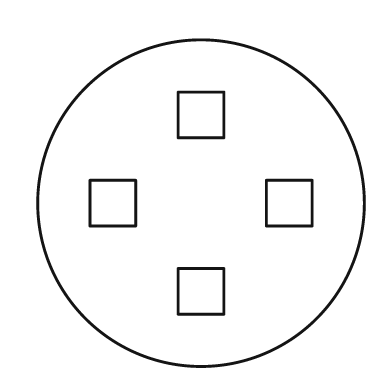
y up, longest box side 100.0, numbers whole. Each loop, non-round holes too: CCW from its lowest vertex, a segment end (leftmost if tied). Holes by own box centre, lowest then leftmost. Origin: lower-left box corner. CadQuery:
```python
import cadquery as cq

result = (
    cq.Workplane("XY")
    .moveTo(50.0, 50.0)
    .circle(50.0)
    .moveTo(43.0, 16.0)
    .lineTo(57.0, 16.0)
    .lineTo(57.0, 30.0)
    .lineTo(43.0, 30.0)
    .close()
    .moveTo(16.0, 43.0)
    .lineTo(30.0, 43.0)
    .lineTo(30.0, 57.0)
    .lineTo(16.0, 57.0)
    .close()
    .moveTo(70.0, 43.0)
    .lineTo(84.0, 43.0)
    .lineTo(84.0, 57.0)
    .lineTo(70.0, 57.0)
    .close()
    .moveTo(43.0, 70.0)
    .lineTo(57.0, 70.0)
    .lineTo(57.0, 84.0)
    .lineTo(43.0, 84.0)
    .close()
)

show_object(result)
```